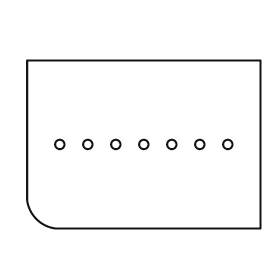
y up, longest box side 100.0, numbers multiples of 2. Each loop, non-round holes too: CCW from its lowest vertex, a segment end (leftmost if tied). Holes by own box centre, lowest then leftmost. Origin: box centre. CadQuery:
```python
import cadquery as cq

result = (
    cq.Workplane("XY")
    .moveTo(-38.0, -36.0)
    .lineTo(50.0, -36.0)
    .lineTo(50.0, 36.0)
    .lineTo(-50.0, 36.0)
    .lineTo(-50.0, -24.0)
    .threePointArc((-46.0, -32.0), (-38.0, -36.0))
    .close()
    .moveTo(-36.0, 0.0)
    .circle(2.0)
    .moveTo(-24.0, 0.0)
    .circle(2.0)
    .moveTo(-12.0, 0.0)
    .circle(2.0)
    .moveTo(0.0, 0.0)
    .circle(2.0)
    .moveTo(12.0, 0.0)
    .circle(2.0)
    .moveTo(24.0, 0.0)
    .circle(2.0)
    .moveTo(36.0, 0.0)
    .circle(2.0)
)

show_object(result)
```